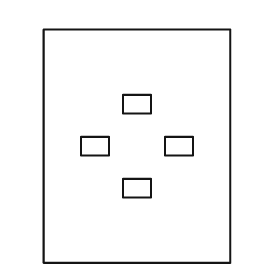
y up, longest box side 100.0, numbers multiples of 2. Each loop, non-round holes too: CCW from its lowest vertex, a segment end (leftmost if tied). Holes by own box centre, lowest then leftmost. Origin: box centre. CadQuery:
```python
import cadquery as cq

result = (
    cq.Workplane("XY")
    .moveTo(-40.0, -50.0)
    .lineTo(40.0, -50.0)
    .lineTo(40.0, 50.0)
    .lineTo(-40.0, 50.0)
    .close()
    .moveTo(-6.0, -22.0)
    .lineTo(6.0, -22.0)
    .lineTo(6.0, -14.0)
    .lineTo(-6.0, -14.0)
    .close()
    .moveTo(-24.0, -4.0)
    .lineTo(-12.0, -4.0)
    .lineTo(-12.0, 4.0)
    .lineTo(-24.0, 4.0)
    .close()
    .moveTo(12.0, -4.0)
    .lineTo(24.0, -4.0)
    .lineTo(24.0, 4.0)
    .lineTo(12.0, 4.0)
    .close()
    .moveTo(-6.0, 14.0)
    .lineTo(6.0, 14.0)
    .lineTo(6.0, 22.0)
    .lineTo(-6.0, 22.0)
    .close()
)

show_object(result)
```